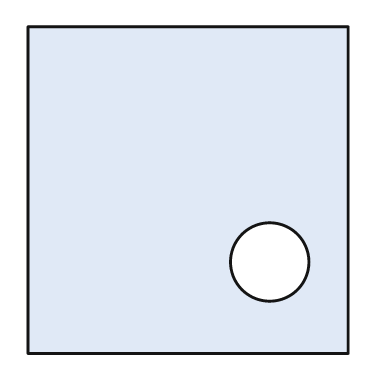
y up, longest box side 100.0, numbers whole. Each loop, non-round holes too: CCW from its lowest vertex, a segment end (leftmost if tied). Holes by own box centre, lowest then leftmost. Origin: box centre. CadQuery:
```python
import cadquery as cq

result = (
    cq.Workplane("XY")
    .moveTo(-49.0, -50.0)
    .lineTo(49.0, -50.0)
    .lineTo(49.0, 50.0)
    .lineTo(-49.0, 50.0)
    .close()
    .moveTo(25.0, -22.0)
    .circle(12.0)
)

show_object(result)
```